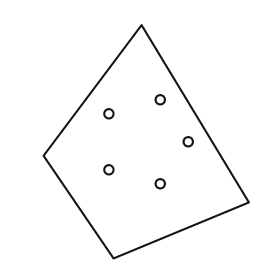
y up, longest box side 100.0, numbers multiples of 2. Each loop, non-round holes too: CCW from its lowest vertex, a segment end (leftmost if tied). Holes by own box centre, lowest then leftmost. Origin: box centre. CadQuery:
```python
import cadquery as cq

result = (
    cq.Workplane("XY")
    .moveTo(-14.0, -50.0)
    .lineTo(44.0, -26.0)
    .lineTo(-2.0, 50.0)
    .lineTo(-44.0, -6.0)
    .close()
    .moveTo(6.0, -18.0)
    .circle(2.0)
    .moveTo(-16.0, -12.0)
    .circle(2.0)
    .moveTo(18.0, 0.0)
    .circle(2.0)
    .moveTo(-16.0, 12.0)
    .circle(2.0)
    .moveTo(6.0, 18.0)
    .circle(2.0)
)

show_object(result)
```